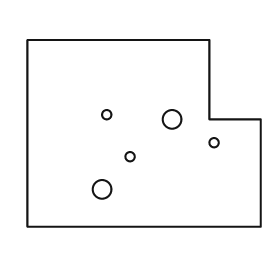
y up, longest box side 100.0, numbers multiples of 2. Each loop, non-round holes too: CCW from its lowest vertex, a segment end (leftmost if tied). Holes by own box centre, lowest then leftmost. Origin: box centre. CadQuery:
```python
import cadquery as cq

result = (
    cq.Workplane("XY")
    .moveTo(-50.0, -40.0)
    .lineTo(50.0, -40.0)
    .lineTo(50.0, 6.0)
    .lineTo(28.0, 6.0)
    .lineTo(28.0, 40.0)
    .lineTo(-50.0, 40.0)
    .close()
    .moveTo(-18.0, -24.0)
    .circle(4.0)
    .moveTo(-6.0, -10.0)
    .circle(2.0)
    .moveTo(30.0, -4.0)
    .circle(2.0)
    .moveTo(12.0, 6.0)
    .circle(4.0)
    .moveTo(-16.0, 8.0)
    .circle(2.0)
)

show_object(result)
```